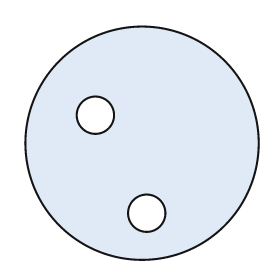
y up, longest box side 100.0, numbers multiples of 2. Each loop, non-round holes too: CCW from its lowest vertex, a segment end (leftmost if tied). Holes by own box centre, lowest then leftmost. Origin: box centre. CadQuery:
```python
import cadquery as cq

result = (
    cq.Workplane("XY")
    .moveTo(0.0, 0.0)
    .circle(50.0)
    .moveTo(2.0, -30.0)
    .circle(8.0)
    .moveTo(-20.0, 12.0)
    .circle(8.0)
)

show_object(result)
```